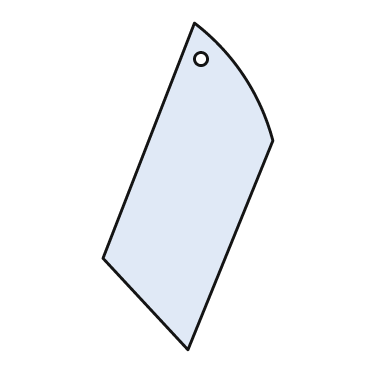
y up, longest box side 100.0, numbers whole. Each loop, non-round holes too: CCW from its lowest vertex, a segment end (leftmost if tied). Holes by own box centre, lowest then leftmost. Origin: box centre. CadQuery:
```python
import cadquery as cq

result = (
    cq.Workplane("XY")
    .moveTo(0.0, -50.0)
    .lineTo(26.0, 14.0)
    .threePointArc((17.0, 34.0), (2.0, 50.0))
    .lineTo(-26.0, -22.0)
    .close()
    .moveTo(4.0, 39.0)
    .circle(2.0)
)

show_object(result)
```